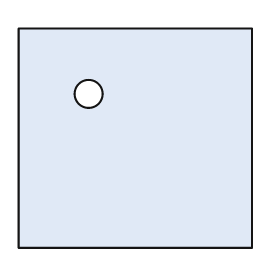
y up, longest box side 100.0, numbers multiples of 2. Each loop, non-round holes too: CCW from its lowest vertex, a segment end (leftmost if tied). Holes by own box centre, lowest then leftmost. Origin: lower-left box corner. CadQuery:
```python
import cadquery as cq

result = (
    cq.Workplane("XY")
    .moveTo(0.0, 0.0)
    .lineTo(100.0, 0.0)
    .lineTo(100.0, 94.0)
    .lineTo(0.0, 94.0)
    .close()
    .moveTo(30.0, 66.0)
    .circle(6.0)
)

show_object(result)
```